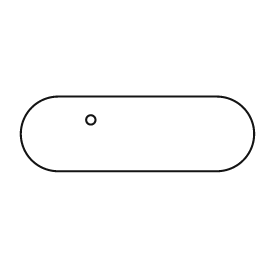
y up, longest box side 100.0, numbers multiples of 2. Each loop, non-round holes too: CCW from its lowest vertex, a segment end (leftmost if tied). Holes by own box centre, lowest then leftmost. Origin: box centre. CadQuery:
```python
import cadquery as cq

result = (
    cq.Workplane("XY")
    .moveTo(-34.0, -16.0)
    .lineTo(34.0, -16.0)
    .threePointArc((50.0, 0.0), (34.0, 16.0))
    .lineTo(-34.0, 16.0)
    .threePointArc((-50.0, 0.0), (-34.0, -16.0))
    .close()
    .moveTo(-20.0, 6.0)
    .circle(2.0)
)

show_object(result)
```